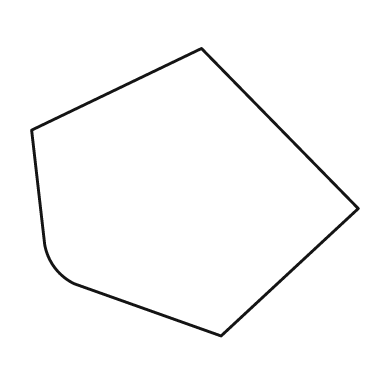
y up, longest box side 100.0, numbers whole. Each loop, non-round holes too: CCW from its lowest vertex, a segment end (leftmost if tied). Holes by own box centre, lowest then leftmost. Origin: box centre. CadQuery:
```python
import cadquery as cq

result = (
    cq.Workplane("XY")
    .moveTo(8.0, -44.0)
    .lineTo(50.0, -5.0)
    .lineTo(2.0, 44.0)
    .lineTo(-50.0, 19.0)
    .lineTo(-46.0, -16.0)
    .threePointArc((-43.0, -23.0), (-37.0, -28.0))
    .close()
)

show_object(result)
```